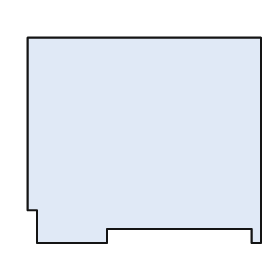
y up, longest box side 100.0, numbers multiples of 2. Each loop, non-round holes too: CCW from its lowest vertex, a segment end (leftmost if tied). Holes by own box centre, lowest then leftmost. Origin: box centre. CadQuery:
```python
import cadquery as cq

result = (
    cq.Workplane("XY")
    .moveTo(-46.0, -44.0)
    .lineTo(-16.0, -44.0)
    .lineTo(-16.0, -38.0)
    .lineTo(46.0, -38.0)
    .lineTo(46.0, -44.0)
    .lineTo(50.0, -44.0)
    .lineTo(50.0, 44.0)
    .lineTo(-50.0, 44.0)
    .lineTo(-50.0, -30.0)
    .lineTo(-46.0, -30.0)
    .close()
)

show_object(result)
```